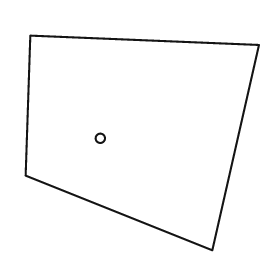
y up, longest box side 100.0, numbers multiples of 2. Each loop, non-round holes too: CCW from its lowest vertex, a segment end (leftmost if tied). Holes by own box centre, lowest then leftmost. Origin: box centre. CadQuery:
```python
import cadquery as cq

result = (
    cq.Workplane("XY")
    .moveTo(30.0, -46.0)
    .lineTo(50.0, 42.0)
    .lineTo(-48.0, 46.0)
    .lineTo(-50.0, -14.0)
    .close()
    .moveTo(-18.0, 2.0)
    .circle(2.0)
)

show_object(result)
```